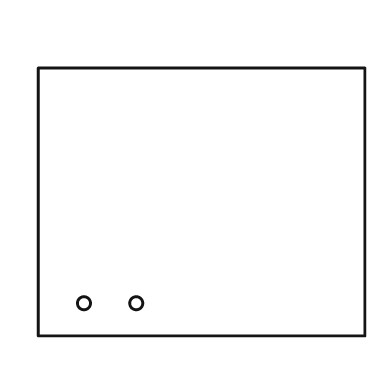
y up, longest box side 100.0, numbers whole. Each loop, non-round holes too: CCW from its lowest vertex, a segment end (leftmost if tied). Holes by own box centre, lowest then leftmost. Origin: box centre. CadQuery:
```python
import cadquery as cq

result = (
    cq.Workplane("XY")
    .moveTo(-50.0, -41.0)
    .lineTo(50.0, -41.0)
    .lineTo(50.0, 41.0)
    .lineTo(-50.0, 41.0)
    .close()
    .moveTo(-36.0, -31.0)
    .circle(2.0)
    .moveTo(-20.0, -31.0)
    .circle(2.0)
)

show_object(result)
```